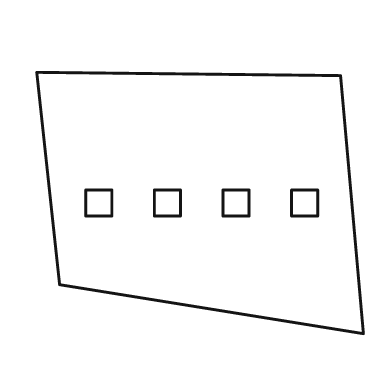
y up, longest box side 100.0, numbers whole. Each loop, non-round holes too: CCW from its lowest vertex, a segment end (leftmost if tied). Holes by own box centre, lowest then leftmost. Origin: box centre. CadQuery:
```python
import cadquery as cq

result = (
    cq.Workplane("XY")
    .moveTo(50.0, -40.0)
    .lineTo(43.0, 39.0)
    .lineTo(-50.0, 40.0)
    .lineTo(-43.0, -25.0)
    .close()
    .moveTo(-35.0, -4.0)
    .lineTo(-27.0, -4.0)
    .lineTo(-27.0, 4.0)
    .lineTo(-35.0, 4.0)
    .close()
    .moveTo(-14.0, -4.0)
    .lineTo(-6.0, -4.0)
    .lineTo(-6.0, 4.0)
    .lineTo(-14.0, 4.0)
    .close()
    .moveTo(7.0, -4.0)
    .lineTo(15.0, -4.0)
    .lineTo(15.0, 4.0)
    .lineTo(7.0, 4.0)
    .close()
    .moveTo(28.0, -4.0)
    .lineTo(36.0, -4.0)
    .lineTo(36.0, 4.0)
    .lineTo(28.0, 4.0)
    .close()
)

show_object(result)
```